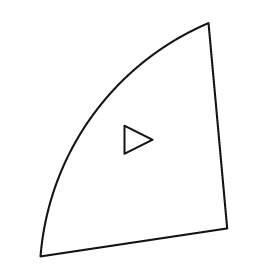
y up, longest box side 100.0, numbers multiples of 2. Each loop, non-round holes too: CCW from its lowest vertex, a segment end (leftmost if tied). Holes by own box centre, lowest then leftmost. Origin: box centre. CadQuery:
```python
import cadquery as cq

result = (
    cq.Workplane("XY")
    .moveTo(-40.0, -50.0)
    .lineTo(40.0, -38.0)
    .lineTo(32.0, 50.0)
    .threePointArc((-18.0, 10.0), (-40.0, -50.0))
    .close()
    .moveTo(-4.0, -6.0)
    .lineTo(8.0, 0.0)
    .lineTo(-4.0, 6.0)
    .close()
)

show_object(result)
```